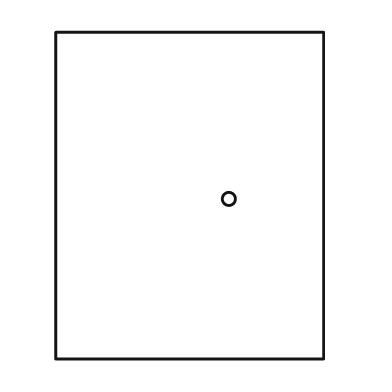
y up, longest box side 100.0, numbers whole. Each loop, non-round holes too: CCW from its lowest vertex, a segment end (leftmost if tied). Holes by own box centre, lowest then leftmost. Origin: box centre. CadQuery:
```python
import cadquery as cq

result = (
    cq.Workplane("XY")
    .moveTo(-41.0, -50.0)
    .lineTo(41.0, -50.0)
    .lineTo(41.0, 50.0)
    .lineTo(-41.0, 50.0)
    .close()
    .moveTo(12.0, -1.0)
    .circle(2.0)
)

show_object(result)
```